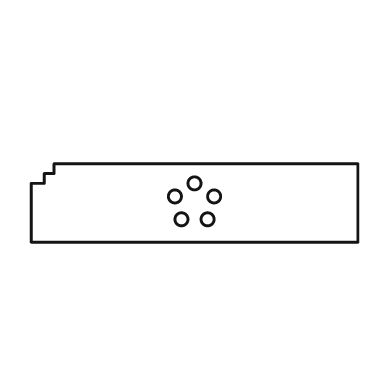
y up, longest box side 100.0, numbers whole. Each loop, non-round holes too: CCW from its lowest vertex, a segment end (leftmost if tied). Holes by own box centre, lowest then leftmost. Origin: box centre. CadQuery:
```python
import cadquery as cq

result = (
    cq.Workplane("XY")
    .moveTo(-50.0, -12.0)
    .lineTo(50.0, -12.0)
    .lineTo(50.0, 12.0)
    .lineTo(-43.0, 12.0)
    .lineTo(-43.0, 9.0)
    .lineTo(-46.0, 9.0)
    .lineTo(-46.0, 6.0)
    .lineTo(-50.0, 6.0)
    .close()
    .moveTo(-4.0, -5.0)
    .circle(2.0)
    .moveTo(4.0, -5.0)
    .circle(2.0)
    .moveTo(-6.0, 2.0)
    .circle(2.0)
    .moveTo(6.0, 2.0)
    .circle(2.0)
    .moveTo(0.0, 6.0)
    .circle(2.0)
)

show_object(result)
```